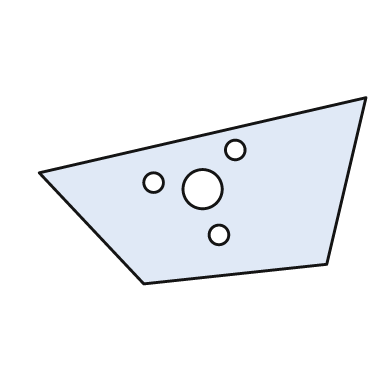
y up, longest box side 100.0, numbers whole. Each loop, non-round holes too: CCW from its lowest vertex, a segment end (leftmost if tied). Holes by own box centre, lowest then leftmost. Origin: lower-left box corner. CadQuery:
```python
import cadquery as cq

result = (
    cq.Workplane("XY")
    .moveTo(32.0, 0.0)
    .lineTo(88.0, 6.0)
    .lineTo(100.0, 57.0)
    .lineTo(0.0, 34.0)
    .close()
    .moveTo(55.0, 15.0)
    .circle(3.0)
    .moveTo(50.0, 29.0)
    .circle(6.0)
    .moveTo(35.0, 31.0)
    .circle(3.0)
    .moveTo(60.0, 41.0)
    .circle(3.0)
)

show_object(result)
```